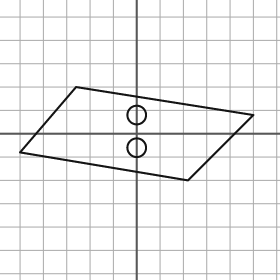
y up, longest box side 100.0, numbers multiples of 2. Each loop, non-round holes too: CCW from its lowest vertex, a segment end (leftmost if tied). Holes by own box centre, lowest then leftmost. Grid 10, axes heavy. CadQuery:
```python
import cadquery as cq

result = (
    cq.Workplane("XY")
    .moveTo(22.0, -20.0)
    .lineTo(50.0, 8.0)
    .lineTo(-26.0, 20.0)
    .lineTo(-50.0, -8.0)
    .close()
    .moveTo(0.0, -6.0)
    .circle(4.0)
    .moveTo(0.0, 8.0)
    .circle(4.0)
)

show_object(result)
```